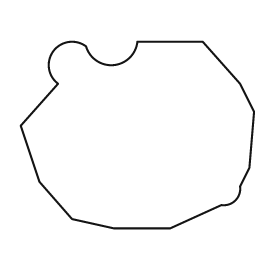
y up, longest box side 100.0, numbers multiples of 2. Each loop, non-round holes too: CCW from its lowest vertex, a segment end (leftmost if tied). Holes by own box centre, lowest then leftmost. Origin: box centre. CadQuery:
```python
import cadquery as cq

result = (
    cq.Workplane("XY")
    .moveTo(-10.0, -40.0)
    .lineTo(14.0, -40.0)
    .lineTo(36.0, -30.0)
    .threePointArc((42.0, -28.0), (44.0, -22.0))
    .lineTo(48.0, -14.0)
    .lineTo(50.0, 10.0)
    .lineTo(44.0, 22.0)
    .lineTo(28.0, 40.0)
    .lineTo(0.0, 40.0)
    .threePointArc((-10.0, 30.0), (-22.0, 38.0))
    .threePointArc((-36.0, 36.0), (-34.0, 22.0))
    .lineTo(-50.0, 4.0)
    .lineTo(-42.0, -20.0)
    .lineTo(-28.0, -36.0)
    .close()
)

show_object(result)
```